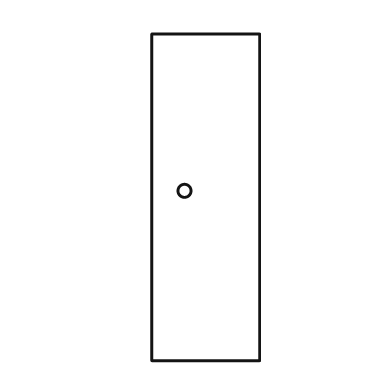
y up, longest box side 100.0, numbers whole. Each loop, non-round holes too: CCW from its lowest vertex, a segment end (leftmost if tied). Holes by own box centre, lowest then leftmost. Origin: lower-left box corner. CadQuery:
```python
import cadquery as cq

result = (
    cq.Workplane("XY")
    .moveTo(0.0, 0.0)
    .lineTo(33.0, 0.0)
    .lineTo(33.0, 100.0)
    .lineTo(0.0, 100.0)
    .close()
    .moveTo(10.0, 52.0)
    .circle(2.0)
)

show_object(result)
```